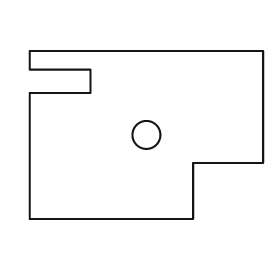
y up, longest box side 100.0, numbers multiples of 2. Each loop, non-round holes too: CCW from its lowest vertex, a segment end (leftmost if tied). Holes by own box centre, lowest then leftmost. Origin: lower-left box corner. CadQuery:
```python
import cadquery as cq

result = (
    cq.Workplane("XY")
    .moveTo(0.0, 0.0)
    .lineTo(70.0, 0.0)
    .lineTo(70.0, 24.0)
    .lineTo(100.0, 24.0)
    .lineTo(100.0, 72.0)
    .lineTo(0.0, 72.0)
    .lineTo(0.0, 64.0)
    .lineTo(26.0, 64.0)
    .lineTo(26.0, 54.0)
    .lineTo(0.0, 54.0)
    .close()
    .moveTo(50.0, 36.0)
    .circle(6.0)
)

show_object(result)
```